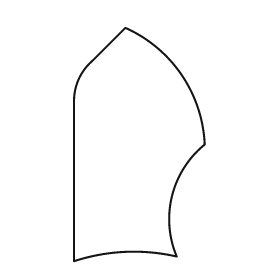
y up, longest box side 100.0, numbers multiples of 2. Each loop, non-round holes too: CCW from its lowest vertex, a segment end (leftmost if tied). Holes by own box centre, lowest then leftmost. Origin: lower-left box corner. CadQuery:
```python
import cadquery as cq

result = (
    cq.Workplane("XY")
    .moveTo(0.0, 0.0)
    .threePointArc((22.0, 4.0), (44.0, 2.0))
    .threePointArc((42.0, 28.0), (56.0, 50.0))
    .threePointArc((46.0, 80.0), (22.0, 100.0))
    .lineTo(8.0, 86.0)
    .threePointArc((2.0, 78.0), (0.0, 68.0))
    .close()
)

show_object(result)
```